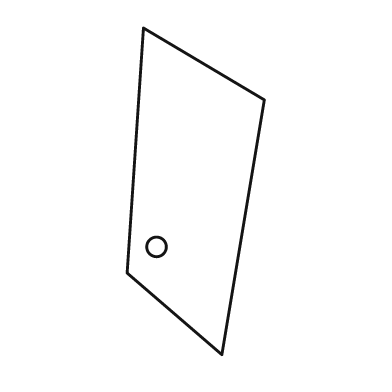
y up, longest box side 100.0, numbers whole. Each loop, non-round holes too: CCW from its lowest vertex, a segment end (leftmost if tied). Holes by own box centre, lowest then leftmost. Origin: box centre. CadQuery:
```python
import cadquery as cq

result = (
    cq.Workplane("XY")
    .moveTo(8.0, -50.0)
    .lineTo(21.0, 28.0)
    .lineTo(-16.0, 50.0)
    .lineTo(-21.0, -25.0)
    .close()
    .moveTo(-12.0, -17.0)
    .circle(3.0)
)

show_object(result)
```